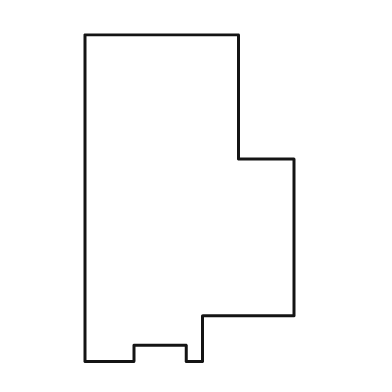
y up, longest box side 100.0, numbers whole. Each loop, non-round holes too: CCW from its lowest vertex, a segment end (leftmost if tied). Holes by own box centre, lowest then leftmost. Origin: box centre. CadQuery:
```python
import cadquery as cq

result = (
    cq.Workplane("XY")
    .moveTo(-32.0, -50.0)
    .lineTo(-17.0, -50.0)
    .lineTo(-17.0, -45.0)
    .lineTo(-1.0, -45.0)
    .lineTo(-1.0, -50.0)
    .lineTo(4.0, -50.0)
    .lineTo(4.0, -36.0)
    .lineTo(32.0, -36.0)
    .lineTo(32.0, 12.0)
    .lineTo(15.0, 12.0)
    .lineTo(15.0, 50.0)
    .lineTo(-32.0, 50.0)
    .close()
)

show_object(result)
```